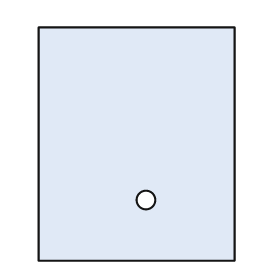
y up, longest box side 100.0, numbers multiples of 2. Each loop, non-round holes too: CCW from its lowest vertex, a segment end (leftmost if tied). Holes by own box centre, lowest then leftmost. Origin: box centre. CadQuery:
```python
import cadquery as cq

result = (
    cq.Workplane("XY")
    .moveTo(-42.0, -50.0)
    .lineTo(42.0, -50.0)
    .lineTo(42.0, 50.0)
    .lineTo(-42.0, 50.0)
    .close()
    .moveTo(4.0, -24.0)
    .circle(4.0)
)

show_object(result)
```